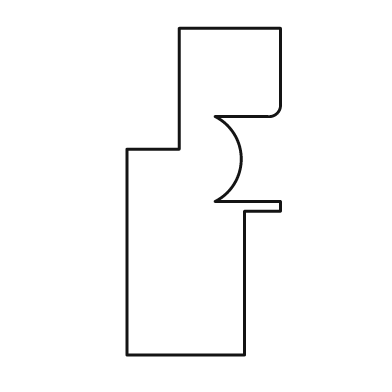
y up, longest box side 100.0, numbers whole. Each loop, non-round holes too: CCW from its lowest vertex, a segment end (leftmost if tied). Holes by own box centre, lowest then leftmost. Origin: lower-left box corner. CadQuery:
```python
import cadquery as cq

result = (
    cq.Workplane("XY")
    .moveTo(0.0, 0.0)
    .lineTo(36.0, 0.0)
    .lineTo(36.0, 44.0)
    .lineTo(47.0, 44.0)
    .lineTo(47.0, 47.0)
    .lineTo(27.0, 47.0)
    .threePointArc((35.0, 60.0), (27.0, 73.0))
    .lineTo(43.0, 73.0)
    .threePointArc((46.0, 74.0), (47.0, 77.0))
    .lineTo(47.0, 100.0)
    .lineTo(16.0, 100.0)
    .lineTo(16.0, 63.0)
    .lineTo(0.0, 63.0)
    .close()
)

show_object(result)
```